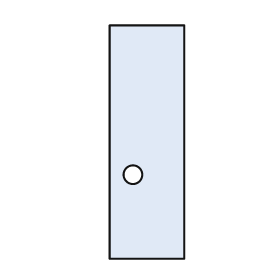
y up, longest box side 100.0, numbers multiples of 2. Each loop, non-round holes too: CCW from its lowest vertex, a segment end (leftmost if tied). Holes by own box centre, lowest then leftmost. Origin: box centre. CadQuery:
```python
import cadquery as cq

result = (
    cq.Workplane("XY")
    .moveTo(-16.0, -50.0)
    .lineTo(16.0, -50.0)
    .lineTo(16.0, 50.0)
    .lineTo(-16.0, 50.0)
    .close()
    .moveTo(-6.0, -14.0)
    .circle(4.0)
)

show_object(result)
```